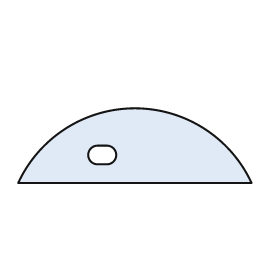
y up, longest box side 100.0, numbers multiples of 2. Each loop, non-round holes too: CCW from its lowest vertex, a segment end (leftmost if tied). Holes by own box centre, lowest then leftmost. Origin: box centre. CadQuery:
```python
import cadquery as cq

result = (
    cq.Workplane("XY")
    .moveTo(-50.0, -16.0)
    .lineTo(50.0, -16.0)
    .threePointArc((0.0, 16.0), (-50.0, -16.0))
    .close()
    .moveTo(-16.0, -8.0)
    .lineTo(-12.0, -8.0)
    .threePointArc((-8.0, -4.0), (-12.0, 0.0))
    .lineTo(-16.0, 0.0)
    .threePointArc((-20.0, -4.0), (-16.0, -8.0))
    .close()
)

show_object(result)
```